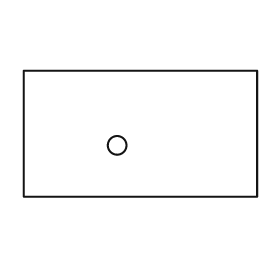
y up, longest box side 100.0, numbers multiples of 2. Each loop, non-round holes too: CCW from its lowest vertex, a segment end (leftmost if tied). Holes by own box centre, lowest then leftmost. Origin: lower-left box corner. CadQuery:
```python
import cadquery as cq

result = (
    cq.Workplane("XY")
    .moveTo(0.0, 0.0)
    .lineTo(100.0, 0.0)
    .lineTo(100.0, 54.0)
    .lineTo(0.0, 54.0)
    .close()
    .moveTo(40.0, 22.0)
    .circle(4.0)
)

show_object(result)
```